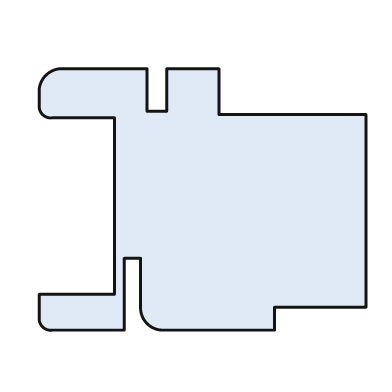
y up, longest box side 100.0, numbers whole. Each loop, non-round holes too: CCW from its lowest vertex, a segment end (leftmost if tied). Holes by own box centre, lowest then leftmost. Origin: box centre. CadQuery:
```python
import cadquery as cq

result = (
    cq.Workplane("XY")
    .moveTo(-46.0, -40.0)
    .lineTo(-24.0, -40.0)
    .lineTo(-24.0, -18.0)
    .lineTo(-19.0, -18.0)
    .lineTo(-19.0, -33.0)
    .threePointArc((-17.0, -38.0), (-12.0, -40.0))
    .lineTo(22.0, -40.0)
    .lineTo(22.0, -33.0)
    .lineTo(50.0, -33.0)
    .lineTo(50.0, 26.0)
    .lineTo(5.0, 26.0)
    .lineTo(5.0, 40.0)
    .lineTo(-11.0, 40.0)
    .lineTo(-11.0, 27.0)
    .lineTo(-17.0, 27.0)
    .lineTo(-17.0, 40.0)
    .lineTo(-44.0, 40.0)
    .threePointArc((-48.0, 38.0), (-50.0, 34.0))
    .lineTo(-50.0, 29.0)
    .threePointArc((-49.0, 26.0), (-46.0, 25.0))
    .lineTo(-27.0, 25.0)
    .lineTo(-27.0, -29.0)
    .lineTo(-50.0, -29.0)
    .lineTo(-50.0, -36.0)
    .threePointArc((-49.0, -39.0), (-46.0, -40.0))
    .close()
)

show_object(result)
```